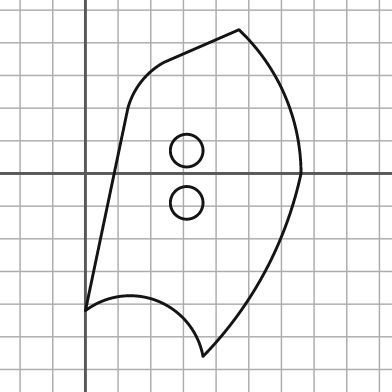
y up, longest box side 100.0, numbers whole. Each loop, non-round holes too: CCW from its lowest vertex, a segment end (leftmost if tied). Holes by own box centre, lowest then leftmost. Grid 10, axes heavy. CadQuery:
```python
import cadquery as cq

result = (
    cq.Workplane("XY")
    .moveTo(36.0, -56.0)
    .threePointArc((55.0, -30.0), (66.0, 0.0))
    .threePointArc((61.0, 24.0), (47.0, 44.0))
    .lineTo(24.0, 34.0)
    .threePointArc((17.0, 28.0), (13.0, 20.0))
    .lineTo(0.0, -42.0)
    .threePointArc((22.0, -39.0), (36.0, -56.0))
    .close()
    .moveTo(31.0, -9.0)
    .circle(5.0)
    .moveTo(31.0, 7.0)
    .circle(5.0)
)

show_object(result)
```